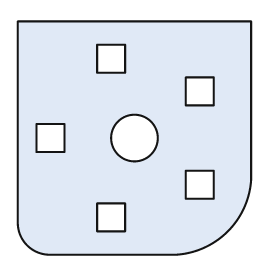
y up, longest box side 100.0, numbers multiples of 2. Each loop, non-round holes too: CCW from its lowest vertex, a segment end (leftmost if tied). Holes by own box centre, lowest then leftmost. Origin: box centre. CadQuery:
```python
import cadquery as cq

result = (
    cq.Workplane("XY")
    .moveTo(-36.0, -50.0)
    .lineTo(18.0, -50.0)
    .threePointArc((40.0, -40.0), (50.0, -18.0))
    .lineTo(50.0, 50.0)
    .lineTo(-50.0, 50.0)
    .lineTo(-50.0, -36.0)
    .threePointArc((-46.0, -46.0), (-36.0, -50.0))
    .close()
    .moveTo(-16.0, -40.0)
    .lineTo(-4.0, -40.0)
    .lineTo(-4.0, -28.0)
    .lineTo(-16.0, -28.0)
    .close()
    .moveTo(22.0, -26.0)
    .lineTo(34.0, -26.0)
    .lineTo(34.0, -14.0)
    .lineTo(22.0, -14.0)
    .close()
    .moveTo(-42.0, -6.0)
    .lineTo(-30.0, -6.0)
    .lineTo(-30.0, 6.0)
    .lineTo(-42.0, 6.0)
    .close()
    .moveTo(0.0, 0.0)
    .circle(10.0)
    .moveTo(22.0, 14.0)
    .lineTo(34.0, 14.0)
    .lineTo(34.0, 26.0)
    .lineTo(22.0, 26.0)
    .close()
    .moveTo(-16.0, 28.0)
    .lineTo(-4.0, 28.0)
    .lineTo(-4.0, 40.0)
    .lineTo(-16.0, 40.0)
    .close()
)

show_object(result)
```